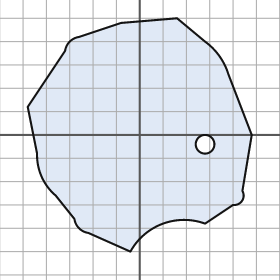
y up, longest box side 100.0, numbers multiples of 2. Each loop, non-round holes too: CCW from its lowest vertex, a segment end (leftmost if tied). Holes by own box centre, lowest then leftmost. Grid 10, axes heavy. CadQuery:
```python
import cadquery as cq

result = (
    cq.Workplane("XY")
    .moveTo(-4.0, -50.0)
    .threePointArc((10.0, -38.0), (28.0, -38.0))
    .lineTo(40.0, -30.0)
    .threePointArc((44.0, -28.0), (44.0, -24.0))
    .lineTo(48.0, 0.0)
    .lineTo(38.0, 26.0)
    .threePointArc((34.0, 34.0), (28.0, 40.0))
    .lineTo(16.0, 50.0)
    .lineTo(-8.0, 48.0)
    .lineTo(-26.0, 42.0)
    .threePointArc((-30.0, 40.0), (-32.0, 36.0))
    .lineTo(-48.0, 12.0)
    .lineTo(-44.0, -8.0)
    .threePointArc((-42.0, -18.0), (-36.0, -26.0))
    .lineTo(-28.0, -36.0)
    .threePointArc((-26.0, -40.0), (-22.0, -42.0))
    .close()
    .moveTo(28.0, -4.0)
    .circle(4.0)
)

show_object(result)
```